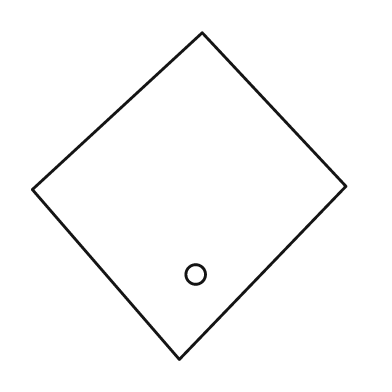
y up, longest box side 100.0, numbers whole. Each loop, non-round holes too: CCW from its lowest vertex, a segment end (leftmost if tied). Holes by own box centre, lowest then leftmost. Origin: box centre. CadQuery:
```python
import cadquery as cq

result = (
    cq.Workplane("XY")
    .moveTo(-3.0, -50.0)
    .lineTo(48.0, 3.0)
    .lineTo(4.0, 50.0)
    .lineTo(-48.0, 2.0)
    .close()
    .moveTo(2.0, -24.0)
    .circle(3.0)
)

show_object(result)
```